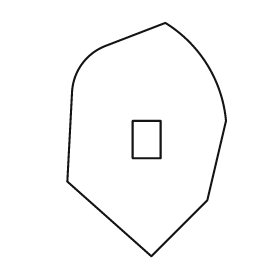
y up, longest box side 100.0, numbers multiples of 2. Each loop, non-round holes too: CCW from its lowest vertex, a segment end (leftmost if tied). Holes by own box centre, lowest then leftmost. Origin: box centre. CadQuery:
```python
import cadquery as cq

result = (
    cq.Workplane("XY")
    .moveTo(2.0, -50.0)
    .lineTo(26.0, -26.0)
    .lineTo(34.0, 8.0)
    .threePointArc((26.0, 32.0), (8.0, 50.0))
    .lineTo(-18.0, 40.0)
    .threePointArc((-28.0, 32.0), (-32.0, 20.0))
    .lineTo(-34.0, -18.0)
    .close()
    .moveTo(-6.0, -8.0)
    .lineTo(6.0, -8.0)
    .lineTo(6.0, 8.0)
    .lineTo(-6.0, 8.0)
    .close()
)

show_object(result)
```